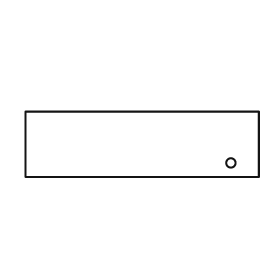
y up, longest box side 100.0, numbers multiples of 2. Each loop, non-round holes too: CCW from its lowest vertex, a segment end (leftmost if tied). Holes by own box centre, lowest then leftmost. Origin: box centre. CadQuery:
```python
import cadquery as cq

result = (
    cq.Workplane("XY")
    .moveTo(-50.0, -14.0)
    .lineTo(50.0, -14.0)
    .lineTo(50.0, 14.0)
    .lineTo(-50.0, 14.0)
    .close()
    .moveTo(38.0, -8.0)
    .circle(2.0)
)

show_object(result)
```